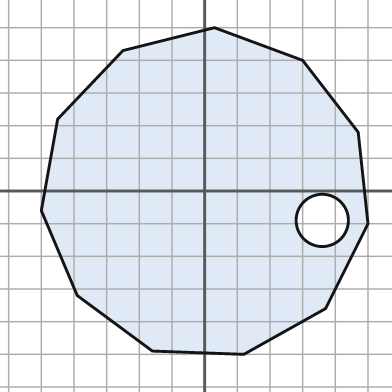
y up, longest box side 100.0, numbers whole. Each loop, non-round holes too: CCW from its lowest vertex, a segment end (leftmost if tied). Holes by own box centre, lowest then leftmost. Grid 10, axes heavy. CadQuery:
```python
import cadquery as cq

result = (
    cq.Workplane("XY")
    .moveTo(12.0, -50.0)
    .lineTo(37.0, -36.0)
    .lineTo(50.0, -10.0)
    .lineTo(47.0, 18.0)
    .lineTo(30.0, 40.0)
    .lineTo(3.0, 50.0)
    .lineTo(-25.0, 43.0)
    .lineTo(-45.0, 22.0)
    .lineTo(-50.0, -6.0)
    .lineTo(-39.0, -32.0)
    .lineTo(-16.0, -49.0)
    .close()
    .moveTo(36.0, -9.0)
    .circle(8.0)
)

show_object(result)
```